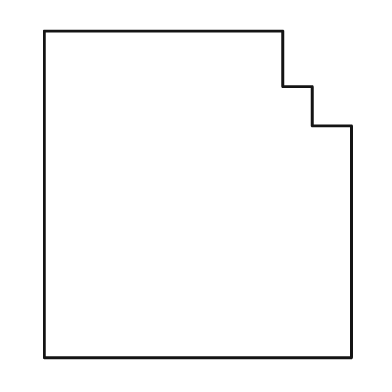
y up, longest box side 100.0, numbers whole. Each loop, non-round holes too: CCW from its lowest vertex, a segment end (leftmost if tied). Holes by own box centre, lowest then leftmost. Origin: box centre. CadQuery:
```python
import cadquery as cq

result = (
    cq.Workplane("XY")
    .moveTo(-47.0, -50.0)
    .lineTo(47.0, -50.0)
    .lineTo(47.0, 21.0)
    .lineTo(35.0, 21.0)
    .lineTo(35.0, 33.0)
    .lineTo(26.0, 33.0)
    .lineTo(26.0, 50.0)
    .lineTo(-47.0, 50.0)
    .close()
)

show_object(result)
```